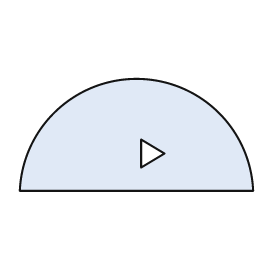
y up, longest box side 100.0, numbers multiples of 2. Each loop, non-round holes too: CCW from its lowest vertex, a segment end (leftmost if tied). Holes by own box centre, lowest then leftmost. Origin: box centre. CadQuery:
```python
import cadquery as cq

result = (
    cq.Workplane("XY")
    .moveTo(-50.0, -24.0)
    .lineTo(50.0, -24.0)
    .threePointArc((0.0, 24.0), (-50.0, -24.0))
    .close()
    .moveTo(2.0, -14.0)
    .lineTo(12.0, -8.0)
    .lineTo(2.0, -2.0)
    .close()
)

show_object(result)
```